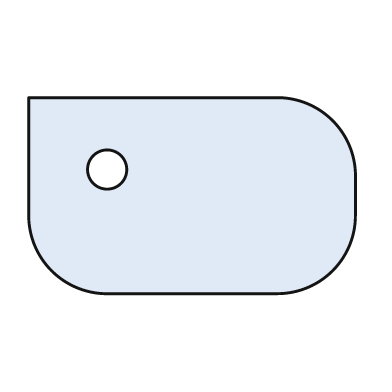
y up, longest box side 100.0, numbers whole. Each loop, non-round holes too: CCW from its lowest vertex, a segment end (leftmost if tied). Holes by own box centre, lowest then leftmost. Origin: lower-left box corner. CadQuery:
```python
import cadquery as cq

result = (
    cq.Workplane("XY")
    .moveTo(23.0, 0.0)
    .lineTo(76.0, 0.0)
    .threePointArc((93.0, 7.0), (100.0, 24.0))
    .lineTo(100.0, 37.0)
    .threePointArc((93.0, 53.0), (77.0, 60.0))
    .lineTo(0.0, 60.0)
    .lineTo(0.0, 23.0)
    .threePointArc((7.0, 7.0), (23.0, 0.0))
    .close()
    .moveTo(24.0, 38.0)
    .circle(6.0)
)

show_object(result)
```